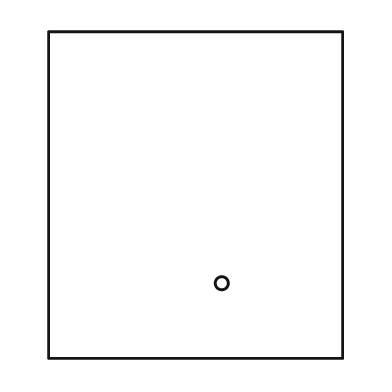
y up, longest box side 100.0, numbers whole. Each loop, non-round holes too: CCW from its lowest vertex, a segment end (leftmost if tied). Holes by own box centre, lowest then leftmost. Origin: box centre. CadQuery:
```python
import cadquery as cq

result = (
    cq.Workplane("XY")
    .moveTo(-45.0, -50.0)
    .lineTo(45.0, -50.0)
    .lineTo(45.0, 50.0)
    .lineTo(-45.0, 50.0)
    .close()
    .moveTo(8.0, -27.0)
    .circle(2.0)
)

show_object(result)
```